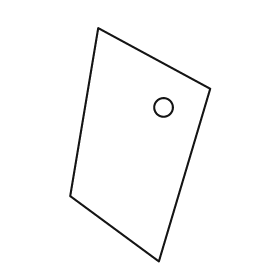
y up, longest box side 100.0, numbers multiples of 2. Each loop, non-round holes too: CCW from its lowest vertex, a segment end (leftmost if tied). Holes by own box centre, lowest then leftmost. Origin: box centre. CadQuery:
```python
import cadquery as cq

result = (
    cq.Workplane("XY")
    .moveTo(8.0, -50.0)
    .lineTo(30.0, 24.0)
    .lineTo(-18.0, 50.0)
    .lineTo(-30.0, -22.0)
    .close()
    .moveTo(10.0, 16.0)
    .circle(4.0)
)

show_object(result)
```